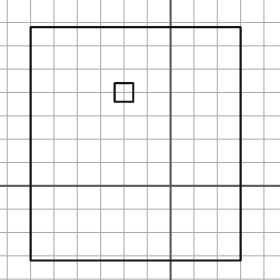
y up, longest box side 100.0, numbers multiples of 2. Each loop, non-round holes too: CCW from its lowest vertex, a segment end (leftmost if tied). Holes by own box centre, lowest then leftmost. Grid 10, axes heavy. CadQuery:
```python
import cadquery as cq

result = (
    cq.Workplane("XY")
    .moveTo(-60.0, -32.0)
    .lineTo(30.0, -32.0)
    .lineTo(30.0, 68.0)
    .lineTo(-60.0, 68.0)
    .close()
    .moveTo(-24.0, 36.0)
    .lineTo(-16.0, 36.0)
    .lineTo(-16.0, 44.0)
    .lineTo(-24.0, 44.0)
    .close()
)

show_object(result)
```